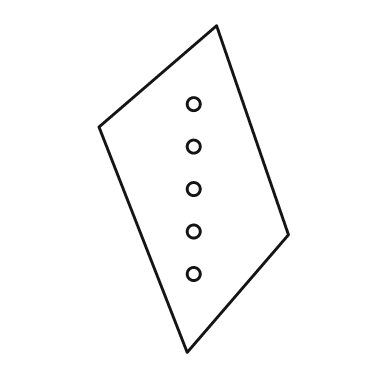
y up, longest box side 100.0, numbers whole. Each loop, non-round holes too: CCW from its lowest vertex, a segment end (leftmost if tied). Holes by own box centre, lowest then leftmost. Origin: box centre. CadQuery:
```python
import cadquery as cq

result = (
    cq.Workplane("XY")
    .moveTo(-2.0, -50.0)
    .lineTo(29.0, -14.0)
    .lineTo(7.0, 50.0)
    .lineTo(-29.0, 19.0)
    .close()
    .moveTo(0.0, -26.0)
    .circle(2.0)
    .moveTo(0.0, -13.0)
    .circle(2.0)
    .moveTo(0.0, 0.0)
    .circle(2.0)
    .moveTo(0.0, 13.0)
    .circle(2.0)
    .moveTo(0.0, 26.0)
    .circle(2.0)
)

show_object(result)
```